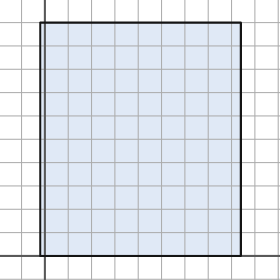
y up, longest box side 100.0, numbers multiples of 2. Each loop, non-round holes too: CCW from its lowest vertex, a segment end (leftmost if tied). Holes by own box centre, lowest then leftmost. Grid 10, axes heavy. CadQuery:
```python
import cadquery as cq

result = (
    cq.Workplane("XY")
    .moveTo(-2.0, 0.0)
    .lineTo(84.0, 0.0)
    .lineTo(84.0, 100.0)
    .lineTo(-2.0, 100.0)
    .close()
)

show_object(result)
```